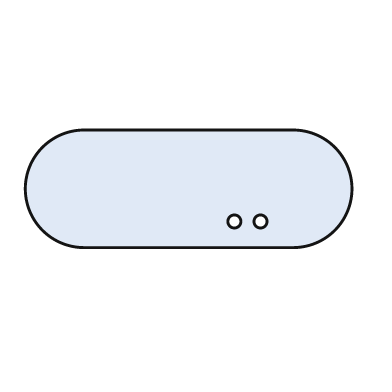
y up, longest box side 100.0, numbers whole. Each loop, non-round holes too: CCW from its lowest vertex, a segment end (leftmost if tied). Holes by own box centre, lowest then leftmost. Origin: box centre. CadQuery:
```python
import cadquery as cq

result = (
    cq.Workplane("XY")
    .moveTo(-32.0, -18.0)
    .lineTo(32.0, -18.0)
    .threePointArc((50.0, 0.0), (32.0, 18.0))
    .lineTo(-32.0, 18.0)
    .threePointArc((-50.0, 0.0), (-32.0, -18.0))
    .close()
    .moveTo(14.0, -10.0)
    .circle(2.0)
    .moveTo(22.0, -10.0)
    .circle(2.0)
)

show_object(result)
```